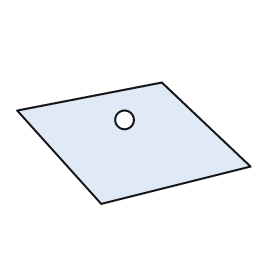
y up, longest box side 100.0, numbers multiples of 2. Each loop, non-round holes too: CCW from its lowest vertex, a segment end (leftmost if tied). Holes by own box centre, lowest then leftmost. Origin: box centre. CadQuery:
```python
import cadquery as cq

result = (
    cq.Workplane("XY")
    .moveTo(-14.0, -26.0)
    .lineTo(50.0, -10.0)
    .lineTo(12.0, 26.0)
    .lineTo(-50.0, 14.0)
    .close()
    .moveTo(-4.0, 10.0)
    .circle(4.0)
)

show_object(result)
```